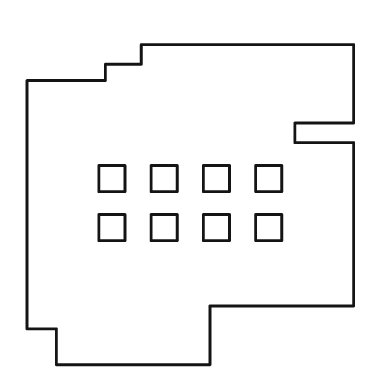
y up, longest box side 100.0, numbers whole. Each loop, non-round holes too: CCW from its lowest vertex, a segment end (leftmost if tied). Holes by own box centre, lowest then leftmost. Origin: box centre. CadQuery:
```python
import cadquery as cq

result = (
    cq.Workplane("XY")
    .moveTo(-41.0, -49.0)
    .lineTo(6.0, -49.0)
    .lineTo(6.0, -31.0)
    .lineTo(50.0, -31.0)
    .lineTo(50.0, 19.0)
    .lineTo(32.0, 19.0)
    .lineTo(32.0, 25.0)
    .lineTo(50.0, 25.0)
    .lineTo(50.0, 49.0)
    .lineTo(-15.0, 49.0)
    .lineTo(-15.0, 43.0)
    .lineTo(-26.0, 43.0)
    .lineTo(-26.0, 38.0)
    .lineTo(-50.0, 38.0)
    .lineTo(-50.0, -38.0)
    .lineTo(-41.0, -38.0)
    .close()
    .moveTo(-28.0, -11.0)
    .lineTo(-20.0, -11.0)
    .lineTo(-20.0, -3.0)
    .lineTo(-28.0, -3.0)
    .close()
    .moveTo(-12.0, -11.0)
    .lineTo(-4.0, -11.0)
    .lineTo(-4.0, -3.0)
    .lineTo(-12.0, -3.0)
    .close()
    .moveTo(4.0, -11.0)
    .lineTo(12.0, -11.0)
    .lineTo(12.0, -3.0)
    .lineTo(4.0, -3.0)
    .close()
    .moveTo(20.0, -11.0)
    .lineTo(28.0, -11.0)
    .lineTo(28.0, -3.0)
    .lineTo(20.0, -3.0)
    .close()
    .moveTo(-28.0, 4.0)
    .lineTo(-20.0, 4.0)
    .lineTo(-20.0, 12.0)
    .lineTo(-28.0, 12.0)
    .close()
    .moveTo(-12.0, 4.0)
    .lineTo(-4.0, 4.0)
    .lineTo(-4.0, 12.0)
    .lineTo(-12.0, 12.0)
    .close()
    .moveTo(4.0, 4.0)
    .lineTo(12.0, 4.0)
    .lineTo(12.0, 12.0)
    .lineTo(4.0, 12.0)
    .close()
    .moveTo(20.0, 4.0)
    .lineTo(28.0, 4.0)
    .lineTo(28.0, 12.0)
    .lineTo(20.0, 12.0)
    .close()
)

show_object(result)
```